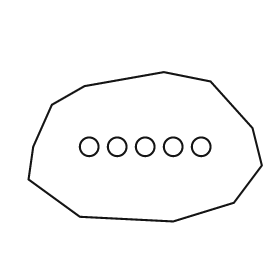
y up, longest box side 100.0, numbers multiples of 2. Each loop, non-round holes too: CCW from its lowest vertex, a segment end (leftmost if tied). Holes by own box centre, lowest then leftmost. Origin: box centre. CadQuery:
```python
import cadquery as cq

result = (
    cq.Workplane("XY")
    .moveTo(12.0, -32.0)
    .lineTo(38.0, -24.0)
    .lineTo(50.0, -8.0)
    .lineTo(46.0, 8.0)
    .lineTo(28.0, 28.0)
    .lineTo(8.0, 32.0)
    .lineTo(-26.0, 26.0)
    .lineTo(-40.0, 18.0)
    .lineTo(-48.0, 0.0)
    .lineTo(-50.0, -14.0)
    .lineTo(-28.0, -30.0)
    .close()
    .moveTo(-24.0, 0.0)
    .circle(4.0)
    .moveTo(-12.0, 0.0)
    .circle(4.0)
    .moveTo(0.0, 0.0)
    .circle(4.0)
    .moveTo(12.0, 0.0)
    .circle(4.0)
    .moveTo(24.0, 0.0)
    .circle(4.0)
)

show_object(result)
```